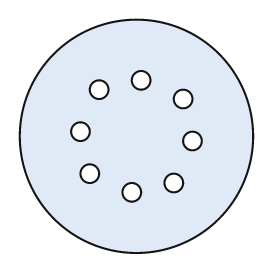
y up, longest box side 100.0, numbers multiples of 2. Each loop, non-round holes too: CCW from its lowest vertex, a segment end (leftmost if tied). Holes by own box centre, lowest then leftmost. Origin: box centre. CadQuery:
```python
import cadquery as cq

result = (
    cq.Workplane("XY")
    .moveTo(0.0, 0.0)
    .circle(50.0)
    .moveTo(-2.0, -24.0)
    .circle(4.0)
    .moveTo(16.0, -20.0)
    .circle(4.0)
    .moveTo(-20.0, -16.0)
    .circle(4.0)
    .moveTo(24.0, -2.0)
    .circle(4.0)
    .moveTo(-24.0, 2.0)
    .circle(4.0)
    .moveTo(20.0, 16.0)
    .circle(4.0)
    .moveTo(-16.0, 20.0)
    .circle(4.0)
    .moveTo(2.0, 24.0)
    .circle(4.0)
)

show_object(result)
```